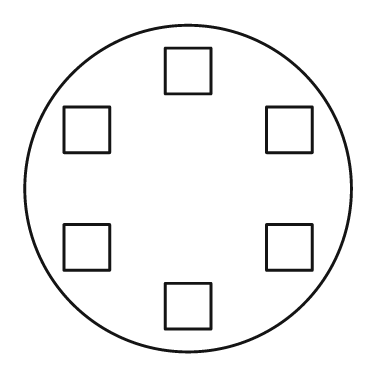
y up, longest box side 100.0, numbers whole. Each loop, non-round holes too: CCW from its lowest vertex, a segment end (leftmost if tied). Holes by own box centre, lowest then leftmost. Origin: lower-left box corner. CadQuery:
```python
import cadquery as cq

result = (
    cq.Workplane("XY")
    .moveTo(50.0, 50.0)
    .circle(50.0)
    .moveTo(43.0, 7.0)
    .lineTo(57.0, 7.0)
    .lineTo(57.0, 21.0)
    .lineTo(43.0, 21.0)
    .close()
    .moveTo(12.0, 25.0)
    .lineTo(26.0, 25.0)
    .lineTo(26.0, 39.0)
    .lineTo(12.0, 39.0)
    .close()
    .moveTo(74.0, 25.0)
    .lineTo(88.0, 25.0)
    .lineTo(88.0, 39.0)
    .lineTo(74.0, 39.0)
    .close()
    .moveTo(12.0, 61.0)
    .lineTo(26.0, 61.0)
    .lineTo(26.0, 75.0)
    .lineTo(12.0, 75.0)
    .close()
    .moveTo(74.0, 61.0)
    .lineTo(88.0, 61.0)
    .lineTo(88.0, 75.0)
    .lineTo(74.0, 75.0)
    .close()
    .moveTo(43.0, 79.0)
    .lineTo(57.0, 79.0)
    .lineTo(57.0, 93.0)
    .lineTo(43.0, 93.0)
    .close()
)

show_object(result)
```